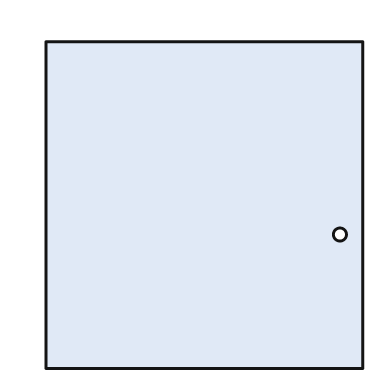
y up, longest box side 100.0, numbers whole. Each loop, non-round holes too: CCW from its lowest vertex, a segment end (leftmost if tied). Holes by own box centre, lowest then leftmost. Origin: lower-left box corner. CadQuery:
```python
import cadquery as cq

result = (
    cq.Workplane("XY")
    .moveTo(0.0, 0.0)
    .lineTo(97.0, 0.0)
    .lineTo(97.0, 100.0)
    .lineTo(0.0, 100.0)
    .close()
    .moveTo(90.0, 41.0)
    .circle(2.0)
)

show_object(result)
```